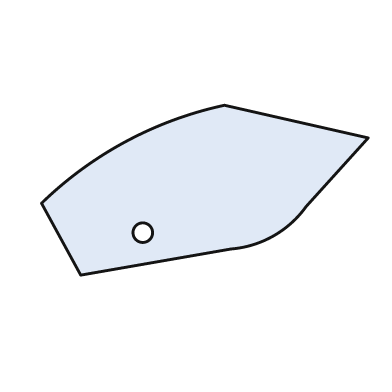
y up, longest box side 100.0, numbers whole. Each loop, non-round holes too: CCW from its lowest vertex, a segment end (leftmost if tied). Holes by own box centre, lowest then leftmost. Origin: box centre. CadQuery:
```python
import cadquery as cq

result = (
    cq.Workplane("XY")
    .moveTo(-38.0, -26.0)
    .lineTo(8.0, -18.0)
    .threePointArc((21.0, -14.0), (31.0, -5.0))
    .lineTo(50.0, 16.0)
    .lineTo(6.0, 26.0)
    .threePointArc((-24.0, 15.0), (-50.0, -4.0))
    .close()
    .moveTo(-19.0, -13.0)
    .circle(3.0)
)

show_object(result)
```